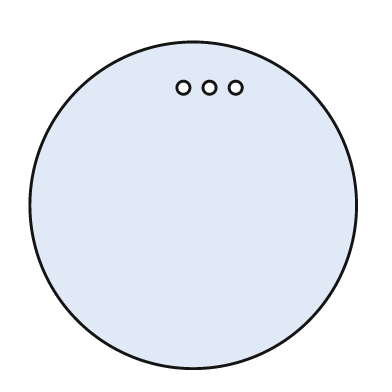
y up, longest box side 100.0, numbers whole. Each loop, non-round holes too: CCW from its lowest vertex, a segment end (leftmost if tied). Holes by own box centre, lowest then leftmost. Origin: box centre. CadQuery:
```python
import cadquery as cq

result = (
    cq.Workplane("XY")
    .moveTo(0.0, 0.0)
    .circle(50.0)
    .moveTo(-3.0, 36.0)
    .circle(2.0)
    .moveTo(5.0, 36.0)
    .circle(2.0)
    .moveTo(13.0, 36.0)
    .circle(2.0)
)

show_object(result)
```